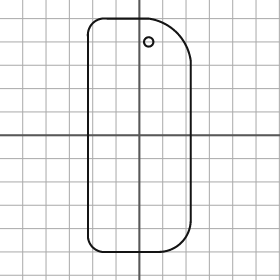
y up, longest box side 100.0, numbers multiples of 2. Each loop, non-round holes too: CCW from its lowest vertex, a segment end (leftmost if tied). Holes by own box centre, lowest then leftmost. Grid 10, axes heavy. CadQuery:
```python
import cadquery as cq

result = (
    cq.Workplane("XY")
    .moveTo(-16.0, -50.0)
    .lineTo(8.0, -50.0)
    .threePointArc((18.0, -46.0), (22.0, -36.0))
    .lineTo(22.0, 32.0)
    .threePointArc((16.0, 44.0), (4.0, 50.0))
    .lineTo(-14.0, 50.0)
    .threePointArc((-20.0, 48.0), (-22.0, 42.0))
    .lineTo(-22.0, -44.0)
    .threePointArc((-20.0, -48.0), (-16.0, -50.0))
    .close()
    .moveTo(4.0, 40.0)
    .circle(2.0)
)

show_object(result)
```